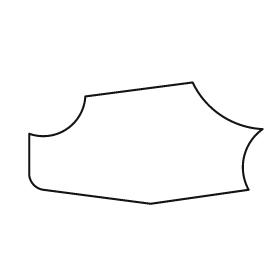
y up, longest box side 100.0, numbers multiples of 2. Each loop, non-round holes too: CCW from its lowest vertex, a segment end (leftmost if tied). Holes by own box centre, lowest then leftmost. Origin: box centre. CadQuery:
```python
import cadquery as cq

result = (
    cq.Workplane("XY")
    .moveTo(2.0, -26.0)
    .lineTo(44.0, -20.0)
    .threePointArc((42.0, -6.0), (50.0, 6.0))
    .threePointArc((32.0, 12.0), (20.0, 26.0))
    .lineTo(-26.0, 20.0)
    .threePointArc((-34.0, 6.0), (-50.0, 4.0))
    .lineTo(-50.0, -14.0)
    .threePointArc((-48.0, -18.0), (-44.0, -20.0))
    .close()
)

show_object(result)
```